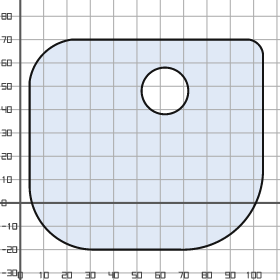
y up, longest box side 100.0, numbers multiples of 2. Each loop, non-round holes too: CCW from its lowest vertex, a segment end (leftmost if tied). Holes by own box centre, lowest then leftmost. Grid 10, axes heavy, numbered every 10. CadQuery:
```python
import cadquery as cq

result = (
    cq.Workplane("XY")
    .moveTo(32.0, -20.0)
    .lineTo(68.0, -20.0)
    .threePointArc((94.0, -10.0), (104.0, 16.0))
    .lineTo(104.0, 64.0)
    .threePointArc((102.0, 68.0), (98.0, 70.0))
    .lineTo(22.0, 70.0)
    .threePointArc((10.0, 64.0), (4.0, 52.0))
    .lineTo(4.0, 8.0)
    .threePointArc((12.0, -12.0), (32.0, -20.0))
    .close()
    .moveTo(62.0, 48.0)
    .circle(10.0)
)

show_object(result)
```